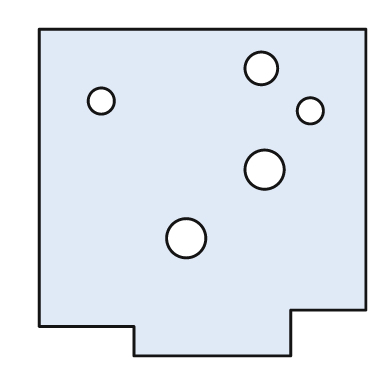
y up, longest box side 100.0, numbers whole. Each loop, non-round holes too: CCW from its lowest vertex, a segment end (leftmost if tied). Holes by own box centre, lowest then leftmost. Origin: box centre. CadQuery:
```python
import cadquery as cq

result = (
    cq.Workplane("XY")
    .moveTo(-21.0, -50.0)
    .lineTo(27.0, -50.0)
    .lineTo(27.0, -36.0)
    .lineTo(50.0, -36.0)
    .lineTo(50.0, 50.0)
    .lineTo(-50.0, 50.0)
    .lineTo(-50.0, -41.0)
    .lineTo(-21.0, -41.0)
    .close()
    .moveTo(-5.0, -14.0)
    .circle(6.0)
    .moveTo(19.0, 7.0)
    .circle(6.0)
    .moveTo(33.0, 25.0)
    .circle(4.0)
    .moveTo(-31.0, 28.0)
    .circle(4.0)
    .moveTo(18.0, 38.0)
    .circle(5.0)
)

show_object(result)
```